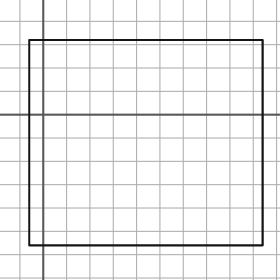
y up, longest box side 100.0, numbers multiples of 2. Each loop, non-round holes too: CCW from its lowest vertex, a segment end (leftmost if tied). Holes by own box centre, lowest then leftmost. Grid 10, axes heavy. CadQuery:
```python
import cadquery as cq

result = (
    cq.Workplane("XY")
    .moveTo(-6.0, -56.0)
    .lineTo(94.0, -56.0)
    .lineTo(94.0, 32.0)
    .lineTo(-6.0, 32.0)
    .close()
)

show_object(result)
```